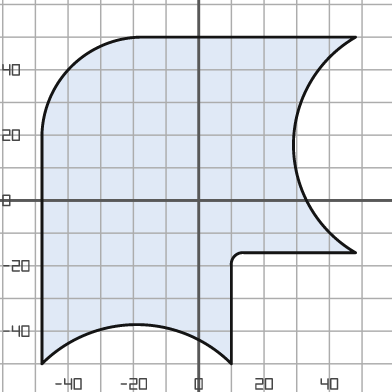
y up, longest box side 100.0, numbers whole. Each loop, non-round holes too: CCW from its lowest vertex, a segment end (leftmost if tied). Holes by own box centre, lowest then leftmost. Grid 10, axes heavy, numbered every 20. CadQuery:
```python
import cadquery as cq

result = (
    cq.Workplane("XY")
    .moveTo(-48.0, -50.0)
    .threePointArc((-19.0, -38.0), (10.0, -50.0))
    .lineTo(10.0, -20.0)
    .threePointArc((11.0, -17.0), (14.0, -16.0))
    .lineTo(48.0, -16.0)
    .threePointArc((29.0, 17.0), (48.0, 50.0))
    .lineTo(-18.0, 50.0)
    .threePointArc((-39.0, 41.0), (-48.0, 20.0))
    .close()
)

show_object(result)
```